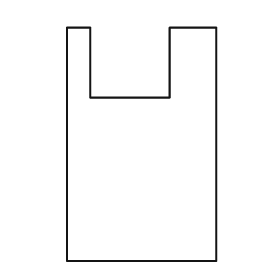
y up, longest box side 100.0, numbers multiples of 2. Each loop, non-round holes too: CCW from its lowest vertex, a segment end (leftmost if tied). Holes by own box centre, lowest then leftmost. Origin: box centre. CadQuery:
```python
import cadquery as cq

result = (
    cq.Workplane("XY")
    .moveTo(-32.0, -50.0)
    .lineTo(32.0, -50.0)
    .lineTo(32.0, 50.0)
    .lineTo(12.0, 50.0)
    .lineTo(12.0, 20.0)
    .lineTo(-22.0, 20.0)
    .lineTo(-22.0, 50.0)
    .lineTo(-32.0, 50.0)
    .close()
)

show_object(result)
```